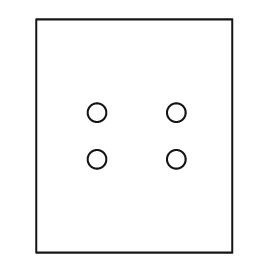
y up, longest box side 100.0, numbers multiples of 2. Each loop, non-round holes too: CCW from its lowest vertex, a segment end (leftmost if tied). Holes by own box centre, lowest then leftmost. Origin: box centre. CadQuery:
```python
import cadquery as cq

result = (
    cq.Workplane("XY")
    .moveTo(-42.0, -50.0)
    .lineTo(42.0, -50.0)
    .lineTo(42.0, 50.0)
    .lineTo(-42.0, 50.0)
    .close()
    .moveTo(-16.0, -10.0)
    .circle(4.0)
    .moveTo(18.0, -10.0)
    .circle(4.0)
    .moveTo(-16.0, 10.0)
    .circle(4.0)
    .moveTo(18.0, 10.0)
    .circle(4.0)
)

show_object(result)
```